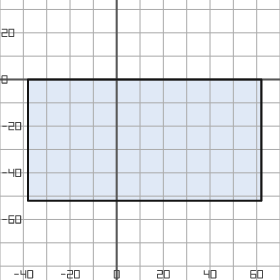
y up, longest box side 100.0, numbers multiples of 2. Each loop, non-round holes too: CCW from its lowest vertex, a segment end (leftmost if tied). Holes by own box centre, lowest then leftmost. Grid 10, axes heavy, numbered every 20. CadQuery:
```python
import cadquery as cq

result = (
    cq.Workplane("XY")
    .moveTo(-38.0, -52.0)
    .lineTo(62.0, -52.0)
    .lineTo(62.0, 0.0)
    .lineTo(-38.0, 0.0)
    .close()
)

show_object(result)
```